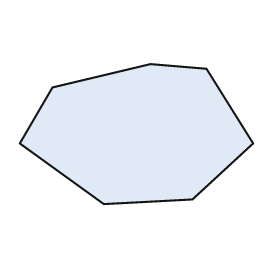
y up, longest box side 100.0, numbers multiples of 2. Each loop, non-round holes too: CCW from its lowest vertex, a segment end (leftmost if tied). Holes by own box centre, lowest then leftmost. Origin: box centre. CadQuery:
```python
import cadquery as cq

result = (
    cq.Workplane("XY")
    .moveTo(-14.0, -30.0)
    .lineTo(24.0, -28.0)
    .lineTo(50.0, -4.0)
    .lineTo(30.0, 28.0)
    .lineTo(6.0, 30.0)
    .lineTo(-36.0, 20.0)
    .lineTo(-50.0, -4.0)
    .close()
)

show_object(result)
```